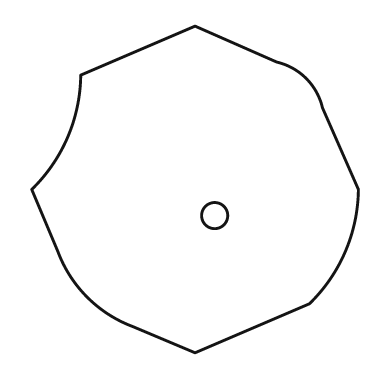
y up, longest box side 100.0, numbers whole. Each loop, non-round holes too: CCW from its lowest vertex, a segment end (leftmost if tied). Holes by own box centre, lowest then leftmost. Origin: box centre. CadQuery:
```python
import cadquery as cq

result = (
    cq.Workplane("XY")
    .moveTo(0.0, -50.0)
    .lineTo(35.0, -35.0)
    .threePointArc((46.0, -19.0), (50.0, 0.0))
    .lineTo(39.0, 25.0)
    .threePointArc((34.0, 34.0), (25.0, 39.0))
    .lineTo(0.0, 50.0)
    .lineTo(-35.0, 35.0)
    .threePointArc((-39.0, 16.0), (-50.0, 0.0))
    .lineTo(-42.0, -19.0)
    .threePointArc((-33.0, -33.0), (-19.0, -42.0))
    .close()
    .moveTo(6.0, -8.0)
    .circle(4.0)
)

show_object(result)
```